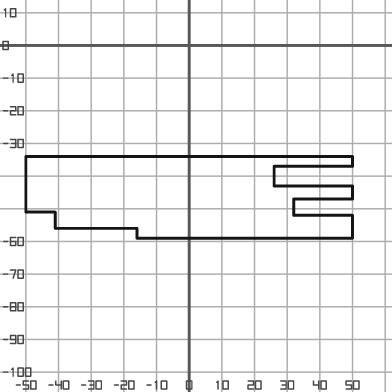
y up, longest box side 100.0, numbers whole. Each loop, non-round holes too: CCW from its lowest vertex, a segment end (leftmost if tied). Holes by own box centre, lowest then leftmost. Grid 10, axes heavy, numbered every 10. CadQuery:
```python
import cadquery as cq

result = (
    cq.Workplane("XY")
    .moveTo(-16.0, -59.0)
    .lineTo(50.0, -59.0)
    .lineTo(50.0, -52.0)
    .lineTo(32.0, -52.0)
    .lineTo(32.0, -47.0)
    .lineTo(50.0, -47.0)
    .lineTo(50.0, -43.0)
    .lineTo(26.0, -43.0)
    .lineTo(26.0, -37.0)
    .lineTo(50.0, -37.0)
    .lineTo(50.0, -34.0)
    .lineTo(-50.0, -34.0)
    .lineTo(-50.0, -51.0)
    .lineTo(-41.0, -51.0)
    .lineTo(-41.0, -56.0)
    .lineTo(-16.0, -56.0)
    .close()
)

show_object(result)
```